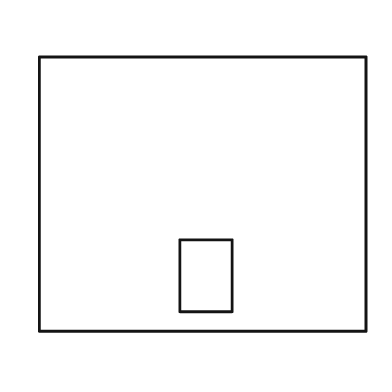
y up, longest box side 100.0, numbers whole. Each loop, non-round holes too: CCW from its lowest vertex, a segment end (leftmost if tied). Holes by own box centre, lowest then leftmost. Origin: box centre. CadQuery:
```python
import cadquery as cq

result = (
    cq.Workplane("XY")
    .moveTo(-50.0, -42.0)
    .lineTo(50.0, -42.0)
    .lineTo(50.0, 42.0)
    .lineTo(-50.0, 42.0)
    .close()
    .moveTo(-7.0, -36.0)
    .lineTo(9.0, -36.0)
    .lineTo(9.0, -14.0)
    .lineTo(-7.0, -14.0)
    .close()
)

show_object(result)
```